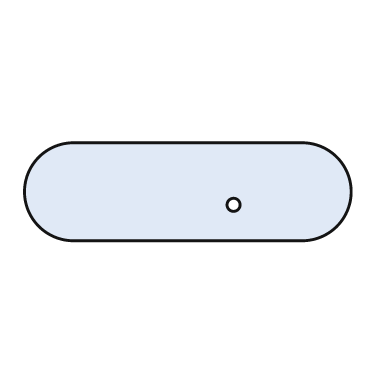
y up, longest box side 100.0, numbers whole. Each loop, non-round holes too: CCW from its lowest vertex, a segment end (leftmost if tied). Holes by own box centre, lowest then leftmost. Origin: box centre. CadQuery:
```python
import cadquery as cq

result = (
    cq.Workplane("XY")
    .moveTo(-35.0, -15.0)
    .lineTo(35.0, -15.0)
    .threePointArc((50.0, 0.0), (35.0, 15.0))
    .lineTo(-35.0, 15.0)
    .threePointArc((-50.0, 0.0), (-35.0, -15.0))
    .close()
    .moveTo(14.0, -4.0)
    .circle(2.0)
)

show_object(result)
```